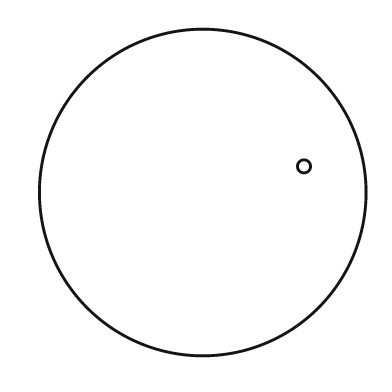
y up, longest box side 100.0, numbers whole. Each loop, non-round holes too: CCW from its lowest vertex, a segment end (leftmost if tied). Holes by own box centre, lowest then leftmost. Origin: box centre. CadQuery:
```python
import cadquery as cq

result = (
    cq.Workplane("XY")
    .moveTo(0.0, 0.0)
    .circle(50.0)
    .moveTo(31.0, 8.0)
    .circle(2.0)
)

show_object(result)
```